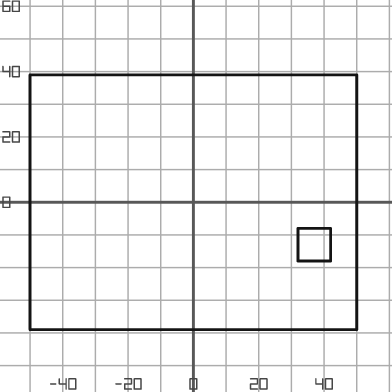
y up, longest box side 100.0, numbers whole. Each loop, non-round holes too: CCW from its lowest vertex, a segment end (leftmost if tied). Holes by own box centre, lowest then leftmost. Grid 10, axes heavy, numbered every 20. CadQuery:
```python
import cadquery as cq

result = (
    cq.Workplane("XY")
    .moveTo(-50.0, -39.0)
    .lineTo(50.0, -39.0)
    .lineTo(50.0, 39.0)
    .lineTo(-50.0, 39.0)
    .close()
    .moveTo(32.0, -18.0)
    .lineTo(42.0, -18.0)
    .lineTo(42.0, -8.0)
    .lineTo(32.0, -8.0)
    .close()
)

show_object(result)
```